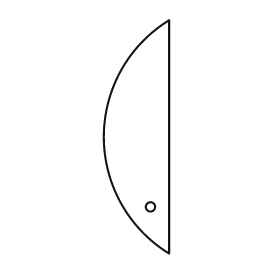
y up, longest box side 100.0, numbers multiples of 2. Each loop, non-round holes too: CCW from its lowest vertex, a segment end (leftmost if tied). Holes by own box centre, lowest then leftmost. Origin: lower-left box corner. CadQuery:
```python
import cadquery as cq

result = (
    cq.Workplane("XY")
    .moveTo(28.0, 0.0)
    .lineTo(28.0, 100.0)
    .threePointArc((0.0, 50.0), (28.0, 0.0))
    .close()
    .moveTo(20.0, 20.0)
    .circle(2.0)
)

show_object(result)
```